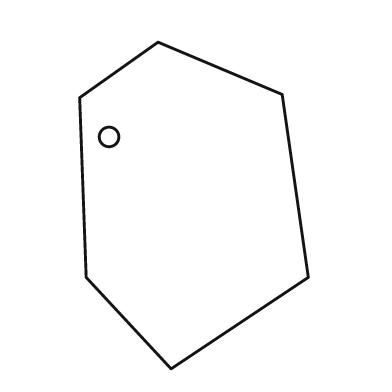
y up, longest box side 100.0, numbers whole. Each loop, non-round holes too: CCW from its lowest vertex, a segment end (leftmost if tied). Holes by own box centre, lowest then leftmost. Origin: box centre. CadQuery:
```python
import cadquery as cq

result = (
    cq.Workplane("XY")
    .moveTo(-7.0, -50.0)
    .lineTo(35.0, -22.0)
    .lineTo(27.0, 34.0)
    .lineTo(-11.0, 50.0)
    .lineTo(-35.0, 33.0)
    .lineTo(-33.0, -22.0)
    .close()
    .moveTo(-26.0, 21.0)
    .circle(3.0)
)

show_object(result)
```